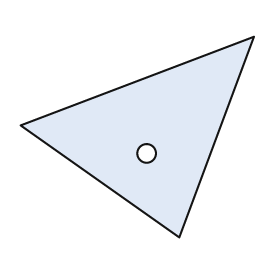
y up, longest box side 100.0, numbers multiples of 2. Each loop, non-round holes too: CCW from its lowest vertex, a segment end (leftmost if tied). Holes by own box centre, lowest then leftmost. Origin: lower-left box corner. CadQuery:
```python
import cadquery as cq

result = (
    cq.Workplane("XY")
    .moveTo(68.0, 0.0)
    .lineTo(100.0, 86.0)
    .lineTo(0.0, 48.0)
    .close()
    .moveTo(54.0, 36.0)
    .circle(4.0)
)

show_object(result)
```